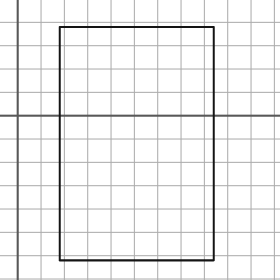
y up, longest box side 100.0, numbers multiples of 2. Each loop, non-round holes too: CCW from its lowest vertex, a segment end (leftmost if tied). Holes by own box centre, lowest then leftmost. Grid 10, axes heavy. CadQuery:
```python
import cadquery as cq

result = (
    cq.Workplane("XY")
    .moveTo(18.0, -62.0)
    .lineTo(84.0, -62.0)
    .lineTo(84.0, 38.0)
    .lineTo(18.0, 38.0)
    .close()
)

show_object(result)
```